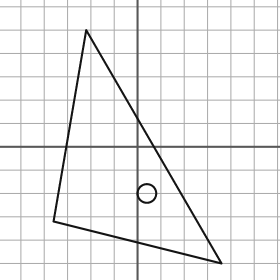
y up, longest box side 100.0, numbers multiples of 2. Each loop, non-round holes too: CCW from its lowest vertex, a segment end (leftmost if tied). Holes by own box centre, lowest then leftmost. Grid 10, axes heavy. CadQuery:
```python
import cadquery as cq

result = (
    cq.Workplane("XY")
    .moveTo(36.0, -50.0)
    .lineTo(-22.0, 50.0)
    .lineTo(-36.0, -32.0)
    .close()
    .moveTo(4.0, -20.0)
    .circle(4.0)
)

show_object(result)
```